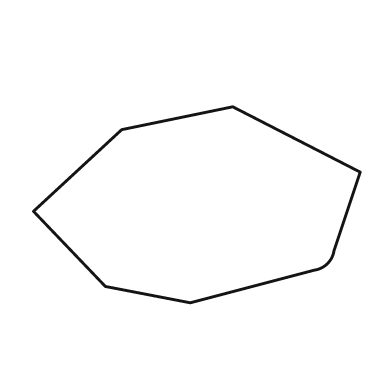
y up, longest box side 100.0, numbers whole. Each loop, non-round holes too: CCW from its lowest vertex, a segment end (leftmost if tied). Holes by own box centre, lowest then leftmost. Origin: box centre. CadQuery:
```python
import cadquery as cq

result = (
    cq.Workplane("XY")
    .moveTo(-2.0, -30.0)
    .lineTo(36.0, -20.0)
    .threePointArc((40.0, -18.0), (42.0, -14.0))
    .lineTo(50.0, 10.0)
    .lineTo(11.0, 30.0)
    .lineTo(-23.0, 23.0)
    .lineTo(-50.0, -2.0)
    .lineTo(-28.0, -25.0)
    .close()
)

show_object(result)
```